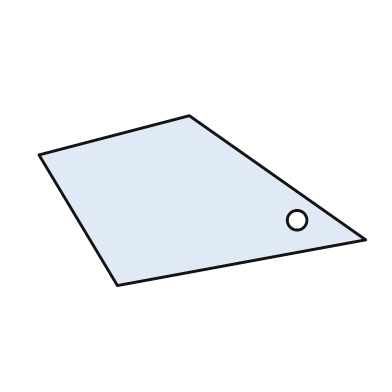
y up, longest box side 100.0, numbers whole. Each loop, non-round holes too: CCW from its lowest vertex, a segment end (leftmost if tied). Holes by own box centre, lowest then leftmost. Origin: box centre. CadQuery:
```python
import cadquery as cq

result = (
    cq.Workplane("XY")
    .moveTo(-26.0, -26.0)
    .lineTo(50.0, -12.0)
    .lineTo(-4.0, 26.0)
    .lineTo(-50.0, 14.0)
    .close()
    .moveTo(29.0, -6.0)
    .circle(3.0)
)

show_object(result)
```